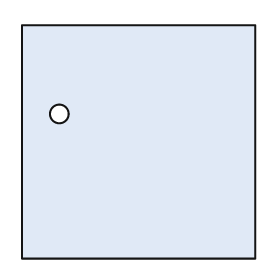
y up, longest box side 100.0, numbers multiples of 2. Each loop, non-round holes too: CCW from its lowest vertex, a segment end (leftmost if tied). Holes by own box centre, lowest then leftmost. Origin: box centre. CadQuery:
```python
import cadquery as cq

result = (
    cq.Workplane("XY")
    .moveTo(-50.0, -50.0)
    .lineTo(50.0, -50.0)
    .lineTo(50.0, 50.0)
    .lineTo(-50.0, 50.0)
    .close()
    .moveTo(-34.0, 12.0)
    .circle(4.0)
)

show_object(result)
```